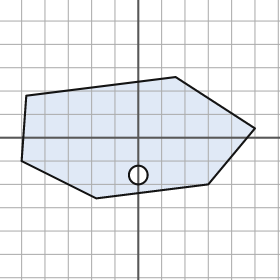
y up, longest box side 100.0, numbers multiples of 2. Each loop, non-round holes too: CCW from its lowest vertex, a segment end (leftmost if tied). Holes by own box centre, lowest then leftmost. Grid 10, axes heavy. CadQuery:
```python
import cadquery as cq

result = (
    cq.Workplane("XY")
    .moveTo(-18.0, -26.0)
    .lineTo(30.0, -20.0)
    .lineTo(50.0, 4.0)
    .lineTo(16.0, 26.0)
    .lineTo(-48.0, 18.0)
    .lineTo(-50.0, -10.0)
    .close()
    .moveTo(0.0, -16.0)
    .circle(4.0)
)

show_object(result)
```